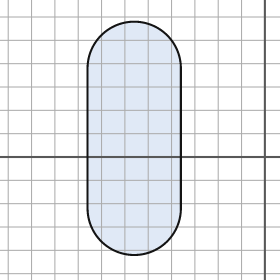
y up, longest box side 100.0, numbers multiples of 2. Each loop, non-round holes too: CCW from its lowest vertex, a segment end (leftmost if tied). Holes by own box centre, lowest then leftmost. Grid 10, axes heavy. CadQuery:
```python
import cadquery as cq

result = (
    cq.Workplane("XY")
    .moveTo(-76.0, -22.0)
    .threePointArc((-56.0, -42.0), (-36.0, -22.0))
    .lineTo(-36.0, 38.0)
    .threePointArc((-56.0, 58.0), (-76.0, 38.0))
    .close()
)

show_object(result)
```